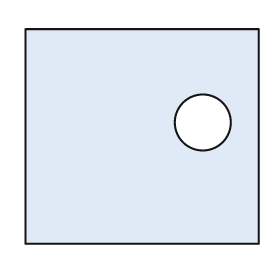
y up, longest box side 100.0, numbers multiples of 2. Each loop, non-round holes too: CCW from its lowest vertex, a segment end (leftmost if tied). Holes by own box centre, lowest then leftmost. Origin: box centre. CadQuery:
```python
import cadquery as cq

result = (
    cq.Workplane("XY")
    .moveTo(-50.0, -46.0)
    .lineTo(50.0, -46.0)
    .lineTo(50.0, 46.0)
    .lineTo(-50.0, 46.0)
    .close()
    .moveTo(26.0, 6.0)
    .circle(12.0)
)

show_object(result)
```